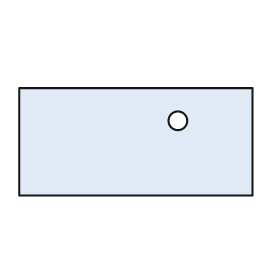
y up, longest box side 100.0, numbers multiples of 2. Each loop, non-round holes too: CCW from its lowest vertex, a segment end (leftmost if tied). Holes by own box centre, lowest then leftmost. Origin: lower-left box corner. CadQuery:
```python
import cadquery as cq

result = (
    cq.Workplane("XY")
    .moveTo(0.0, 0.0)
    .lineTo(100.0, 0.0)
    .lineTo(100.0, 46.0)
    .lineTo(0.0, 46.0)
    .close()
    .moveTo(68.0, 32.0)
    .circle(4.0)
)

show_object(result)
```